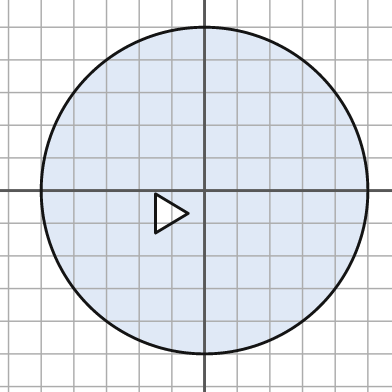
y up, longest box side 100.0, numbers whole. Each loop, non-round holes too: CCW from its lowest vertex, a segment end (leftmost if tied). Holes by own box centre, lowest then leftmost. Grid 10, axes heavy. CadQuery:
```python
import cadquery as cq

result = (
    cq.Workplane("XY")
    .moveTo(0.0, 0.0)
    .circle(50.0)
    .moveTo(-15.0, -13.0)
    .lineTo(-5.0, -7.0)
    .lineTo(-15.0, -1.0)
    .close()
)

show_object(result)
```